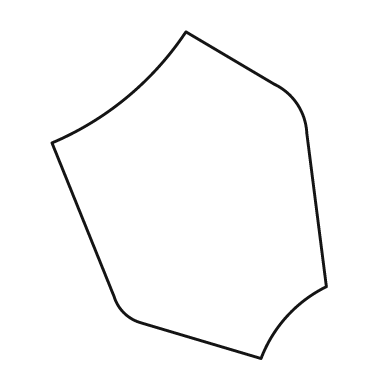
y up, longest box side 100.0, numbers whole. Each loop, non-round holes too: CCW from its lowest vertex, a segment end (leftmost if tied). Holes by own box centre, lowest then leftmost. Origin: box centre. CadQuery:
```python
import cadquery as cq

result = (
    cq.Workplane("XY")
    .moveTo(22.0, -50.0)
    .threePointArc((30.0, -37.0), (42.0, -28.0))
    .lineTo(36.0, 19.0)
    .threePointArc((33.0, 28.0), (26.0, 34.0))
    .lineTo(-1.0, 50.0)
    .threePointArc((-19.0, 30.0), (-42.0, 16.0))
    .lineTo(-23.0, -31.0)
    .threePointArc((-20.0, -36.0), (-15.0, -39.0))
    .close()
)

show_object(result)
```